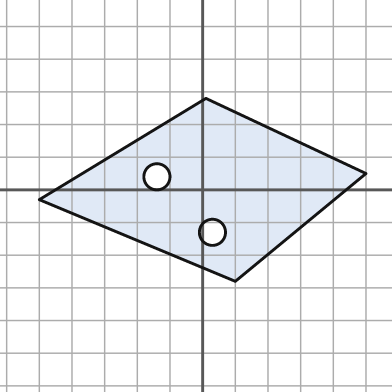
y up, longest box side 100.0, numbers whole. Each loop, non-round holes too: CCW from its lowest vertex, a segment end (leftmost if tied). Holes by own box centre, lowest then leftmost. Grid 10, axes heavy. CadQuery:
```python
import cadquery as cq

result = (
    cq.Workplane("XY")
    .moveTo(10.0, -28.0)
    .lineTo(50.0, 5.0)
    .lineTo(1.0, 28.0)
    .lineTo(-50.0, -3.0)
    .close()
    .moveTo(3.0, -13.0)
    .circle(4.0)
    .moveTo(-14.0, 4.0)
    .circle(4.0)
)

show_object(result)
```